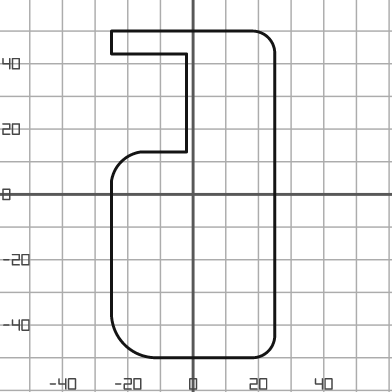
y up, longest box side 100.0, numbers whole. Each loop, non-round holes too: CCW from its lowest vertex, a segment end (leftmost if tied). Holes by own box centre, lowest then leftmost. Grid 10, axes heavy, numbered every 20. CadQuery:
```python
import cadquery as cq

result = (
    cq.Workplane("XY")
    .moveTo(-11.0, -50.0)
    .lineTo(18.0, -50.0)
    .threePointArc((23.0, -48.0), (25.0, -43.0))
    .lineTo(25.0, 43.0)
    .threePointArc((23.0, 48.0), (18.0, 50.0))
    .lineTo(-25.0, 50.0)
    .lineTo(-25.0, 43.0)
    .lineTo(-2.0, 43.0)
    .lineTo(-2.0, 13.0)
    .lineTo(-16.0, 13.0)
    .threePointArc((-22.0, 10.0), (-25.0, 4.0))
    .lineTo(-25.0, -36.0)
    .threePointArc((-21.0, -46.0), (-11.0, -50.0))
    .close()
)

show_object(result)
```